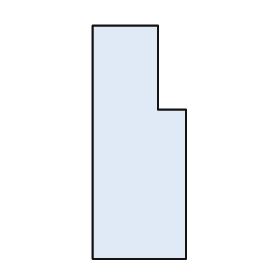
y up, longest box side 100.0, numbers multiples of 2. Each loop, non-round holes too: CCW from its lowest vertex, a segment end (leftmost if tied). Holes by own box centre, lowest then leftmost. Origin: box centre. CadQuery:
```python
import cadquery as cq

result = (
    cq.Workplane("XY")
    .moveTo(-20.0, -50.0)
    .lineTo(20.0, -50.0)
    .lineTo(20.0, 14.0)
    .lineTo(8.0, 14.0)
    .lineTo(8.0, 50.0)
    .lineTo(-20.0, 50.0)
    .close()
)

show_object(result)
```